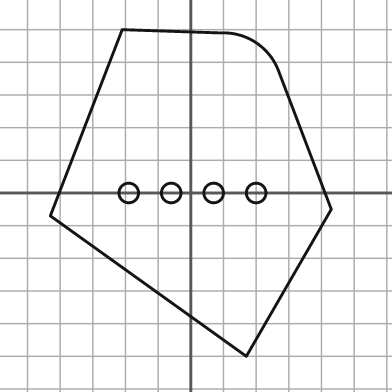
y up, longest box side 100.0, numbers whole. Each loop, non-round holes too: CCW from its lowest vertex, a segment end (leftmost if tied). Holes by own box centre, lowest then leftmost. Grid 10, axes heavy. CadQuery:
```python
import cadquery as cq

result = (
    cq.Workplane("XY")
    .moveTo(17.0, -50.0)
    .lineTo(43.0, -5.0)
    .lineTo(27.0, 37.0)
    .threePointArc((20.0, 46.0), (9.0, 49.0))
    .lineTo(-21.0, 50.0)
    .lineTo(-43.0, -7.0)
    .close()
    .moveTo(-19.0, 0.0)
    .circle(3.0)
    .moveTo(-6.0, 0.0)
    .circle(3.0)
    .moveTo(7.0, 0.0)
    .circle(3.0)
    .moveTo(20.0, 0.0)
    .circle(3.0)
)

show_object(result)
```